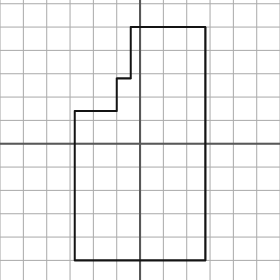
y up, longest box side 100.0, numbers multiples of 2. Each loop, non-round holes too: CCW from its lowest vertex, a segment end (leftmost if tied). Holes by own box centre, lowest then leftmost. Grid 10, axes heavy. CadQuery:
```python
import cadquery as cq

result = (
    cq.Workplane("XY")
    .moveTo(-28.0, -50.0)
    .lineTo(28.0, -50.0)
    .lineTo(28.0, 50.0)
    .lineTo(-4.0, 50.0)
    .lineTo(-4.0, 28.0)
    .lineTo(-10.0, 28.0)
    .lineTo(-10.0, 14.0)
    .lineTo(-28.0, 14.0)
    .close()
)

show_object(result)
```